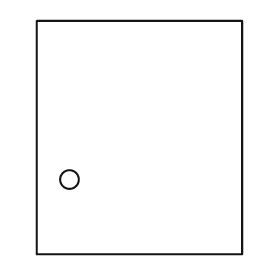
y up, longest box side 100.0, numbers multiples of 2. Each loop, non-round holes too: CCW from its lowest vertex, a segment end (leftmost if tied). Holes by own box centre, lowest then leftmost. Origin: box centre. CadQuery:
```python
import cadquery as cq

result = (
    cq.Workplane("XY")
    .moveTo(-44.0, -50.0)
    .lineTo(44.0, -50.0)
    .lineTo(44.0, 50.0)
    .lineTo(-44.0, 50.0)
    .close()
    .moveTo(-30.0, -18.0)
    .circle(4.0)
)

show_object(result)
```